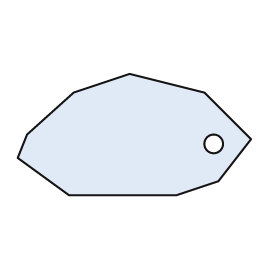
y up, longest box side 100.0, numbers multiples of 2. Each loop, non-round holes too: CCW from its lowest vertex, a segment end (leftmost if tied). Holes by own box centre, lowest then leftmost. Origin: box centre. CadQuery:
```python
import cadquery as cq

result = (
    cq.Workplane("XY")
    .moveTo(-28.0, -26.0)
    .lineTo(18.0, -26.0)
    .lineTo(36.0, -20.0)
    .lineTo(50.0, -2.0)
    .lineTo(30.0, 18.0)
    .lineTo(-2.0, 26.0)
    .lineTo(-26.0, 18.0)
    .lineTo(-46.0, 0.0)
    .lineTo(-50.0, -10.0)
    .close()
    .moveTo(34.0, -4.0)
    .circle(4.0)
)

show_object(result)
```